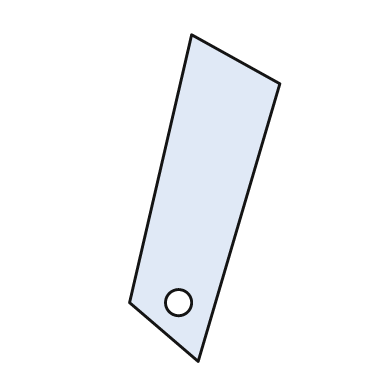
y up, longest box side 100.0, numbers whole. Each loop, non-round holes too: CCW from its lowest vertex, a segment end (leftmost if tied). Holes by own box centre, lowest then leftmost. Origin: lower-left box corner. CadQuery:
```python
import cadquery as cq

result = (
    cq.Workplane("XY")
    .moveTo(21.0, 0.0)
    .lineTo(46.0, 85.0)
    .lineTo(19.0, 100.0)
    .lineTo(0.0, 18.0)
    .close()
    .moveTo(15.0, 18.0)
    .circle(4.0)
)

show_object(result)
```